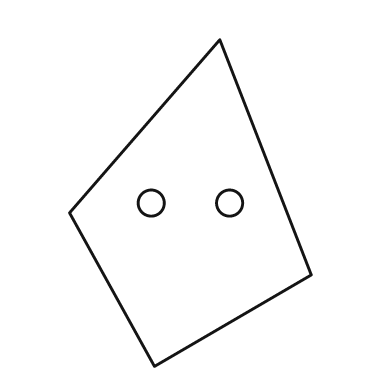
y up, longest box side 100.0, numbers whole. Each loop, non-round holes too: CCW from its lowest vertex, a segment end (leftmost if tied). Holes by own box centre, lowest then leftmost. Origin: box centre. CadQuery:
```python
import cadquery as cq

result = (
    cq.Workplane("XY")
    .moveTo(-11.0, -50.0)
    .lineTo(37.0, -22.0)
    .lineTo(9.0, 50.0)
    .lineTo(-37.0, -3.0)
    .close()
    .moveTo(-12.0, 0.0)
    .circle(4.0)
    .moveTo(12.0, 0.0)
    .circle(4.0)
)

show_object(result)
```